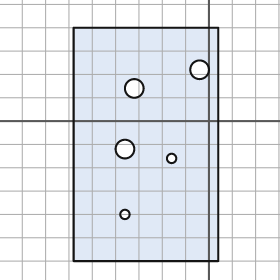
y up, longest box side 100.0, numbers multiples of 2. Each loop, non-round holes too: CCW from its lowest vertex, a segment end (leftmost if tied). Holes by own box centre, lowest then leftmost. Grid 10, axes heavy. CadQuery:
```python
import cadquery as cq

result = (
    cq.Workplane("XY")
    .moveTo(-58.0, -60.0)
    .lineTo(4.0, -60.0)
    .lineTo(4.0, 40.0)
    .lineTo(-58.0, 40.0)
    .close()
    .moveTo(-36.0, -40.0)
    .circle(2.0)
    .moveTo(-16.0, -16.0)
    .circle(2.0)
    .moveTo(-36.0, -12.0)
    .circle(4.0)
    .moveTo(-32.0, 14.0)
    .circle(4.0)
    .moveTo(-4.0, 22.0)
    .circle(4.0)
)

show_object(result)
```